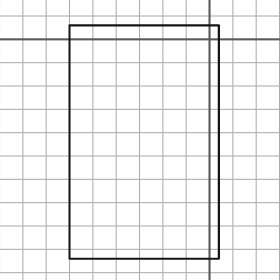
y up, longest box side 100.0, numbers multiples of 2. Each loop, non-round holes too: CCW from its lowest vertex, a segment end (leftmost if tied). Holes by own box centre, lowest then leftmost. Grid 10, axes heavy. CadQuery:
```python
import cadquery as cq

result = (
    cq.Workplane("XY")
    .moveTo(-60.0, -94.0)
    .lineTo(4.0, -94.0)
    .lineTo(4.0, 6.0)
    .lineTo(-60.0, 6.0)
    .close()
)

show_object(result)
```